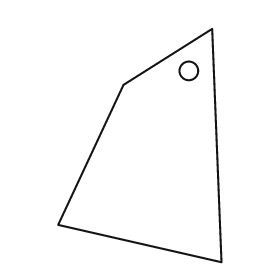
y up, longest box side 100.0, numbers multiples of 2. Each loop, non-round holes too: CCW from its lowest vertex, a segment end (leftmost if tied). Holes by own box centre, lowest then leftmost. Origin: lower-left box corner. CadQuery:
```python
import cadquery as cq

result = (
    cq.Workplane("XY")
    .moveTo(70.0, 0.0)
    .lineTo(66.0, 100.0)
    .lineTo(28.0, 76.0)
    .lineTo(0.0, 16.0)
    .close()
    .moveTo(56.0, 82.0)
    .circle(4.0)
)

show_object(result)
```